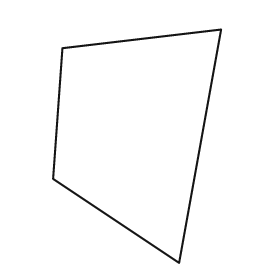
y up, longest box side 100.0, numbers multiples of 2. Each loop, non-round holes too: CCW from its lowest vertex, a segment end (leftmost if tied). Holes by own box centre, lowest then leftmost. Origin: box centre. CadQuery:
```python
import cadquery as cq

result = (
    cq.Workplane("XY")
    .moveTo(18.0, -50.0)
    .lineTo(36.0, 50.0)
    .lineTo(-32.0, 42.0)
    .lineTo(-36.0, -14.0)
    .close()
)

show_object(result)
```